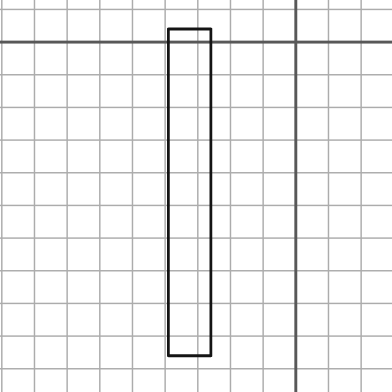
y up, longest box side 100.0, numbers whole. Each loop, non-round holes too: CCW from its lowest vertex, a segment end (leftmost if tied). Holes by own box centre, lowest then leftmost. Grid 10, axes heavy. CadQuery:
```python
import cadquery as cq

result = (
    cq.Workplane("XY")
    .moveTo(-39.0, -96.0)
    .lineTo(-26.0, -96.0)
    .lineTo(-26.0, 4.0)
    .lineTo(-39.0, 4.0)
    .close()
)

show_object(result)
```